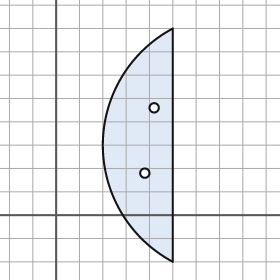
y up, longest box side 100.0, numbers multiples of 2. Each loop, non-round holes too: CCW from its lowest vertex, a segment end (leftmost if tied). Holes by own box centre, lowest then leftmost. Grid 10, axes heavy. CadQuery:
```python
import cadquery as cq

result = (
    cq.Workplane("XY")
    .moveTo(50.0, -20.0)
    .lineTo(50.0, 80.0)
    .threePointArc((20.0, 30.0), (50.0, -20.0))
    .close()
    .moveTo(38.0, 18.0)
    .circle(2.0)
    .moveTo(42.0, 46.0)
    .circle(2.0)
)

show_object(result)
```